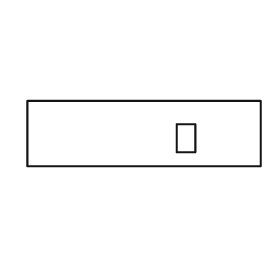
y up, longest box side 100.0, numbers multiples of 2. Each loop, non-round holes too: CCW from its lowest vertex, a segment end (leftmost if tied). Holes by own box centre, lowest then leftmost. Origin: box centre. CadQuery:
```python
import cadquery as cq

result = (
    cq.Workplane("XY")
    .moveTo(-50.0, -14.0)
    .lineTo(50.0, -14.0)
    .lineTo(50.0, 14.0)
    .lineTo(-50.0, 14.0)
    .close()
    .moveTo(14.0, -8.0)
    .lineTo(22.0, -8.0)
    .lineTo(22.0, 4.0)
    .lineTo(14.0, 4.0)
    .close()
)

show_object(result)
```